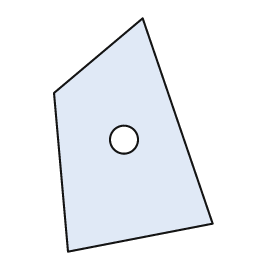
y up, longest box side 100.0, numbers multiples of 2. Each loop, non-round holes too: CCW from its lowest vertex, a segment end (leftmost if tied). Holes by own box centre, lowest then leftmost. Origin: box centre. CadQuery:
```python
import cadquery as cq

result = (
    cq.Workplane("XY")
    .moveTo(-28.0, -50.0)
    .lineTo(34.0, -38.0)
    .lineTo(4.0, 50.0)
    .lineTo(-34.0, 18.0)
    .close()
    .moveTo(-4.0, -2.0)
    .circle(6.0)
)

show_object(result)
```